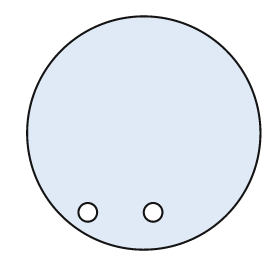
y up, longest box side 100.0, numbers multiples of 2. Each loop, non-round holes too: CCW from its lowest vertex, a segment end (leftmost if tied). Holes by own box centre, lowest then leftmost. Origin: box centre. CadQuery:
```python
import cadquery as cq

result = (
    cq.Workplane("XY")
    .moveTo(0.0, 0.0)
    .circle(50.0)
    .moveTo(-24.0, -34.0)
    .circle(4.0)
    .moveTo(4.0, -34.0)
    .circle(4.0)
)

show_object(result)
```